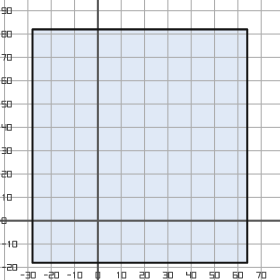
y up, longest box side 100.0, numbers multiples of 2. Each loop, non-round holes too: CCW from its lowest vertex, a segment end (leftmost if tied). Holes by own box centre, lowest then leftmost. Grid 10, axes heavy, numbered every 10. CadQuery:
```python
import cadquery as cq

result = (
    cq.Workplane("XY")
    .moveTo(-28.0, -18.0)
    .lineTo(64.0, -18.0)
    .lineTo(64.0, 82.0)
    .lineTo(-28.0, 82.0)
    .close()
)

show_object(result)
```